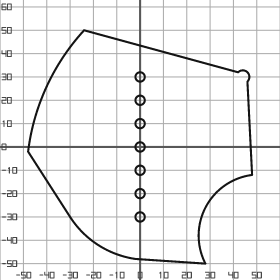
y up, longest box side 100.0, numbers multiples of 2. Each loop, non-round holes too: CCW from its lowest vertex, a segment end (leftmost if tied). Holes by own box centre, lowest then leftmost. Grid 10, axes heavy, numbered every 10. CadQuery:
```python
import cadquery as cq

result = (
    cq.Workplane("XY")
    .moveTo(28.0, -50.0)
    .threePointArc((28.0, -26.0), (48.0, -12.0))
    .lineTo(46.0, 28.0)
    .threePointArc((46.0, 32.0), (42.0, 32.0))
    .lineTo(-24.0, 50.0)
    .threePointArc((-40.0, 26.0), (-48.0, -2.0))
    .lineTo(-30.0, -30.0)
    .threePointArc((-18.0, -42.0), (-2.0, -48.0))
    .close()
    .moveTo(0.0, -30.0)
    .circle(2.0)
    .moveTo(0.0, -20.0)
    .circle(2.0)
    .moveTo(0.0, -10.0)
    .circle(2.0)
    .moveTo(0.0, 0.0)
    .circle(2.0)
    .moveTo(0.0, 10.0)
    .circle(2.0)
    .moveTo(0.0, 20.0)
    .circle(2.0)
    .moveTo(0.0, 30.0)
    .circle(2.0)
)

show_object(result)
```